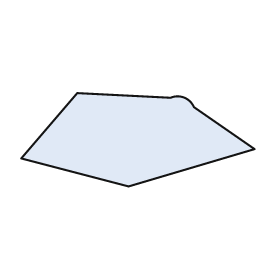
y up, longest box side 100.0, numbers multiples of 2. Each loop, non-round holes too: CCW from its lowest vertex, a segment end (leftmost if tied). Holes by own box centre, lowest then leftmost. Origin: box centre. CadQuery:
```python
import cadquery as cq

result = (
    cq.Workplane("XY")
    .moveTo(-4.0, -20.0)
    .lineTo(50.0, -4.0)
    .lineTo(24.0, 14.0)
    .threePointArc((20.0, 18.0), (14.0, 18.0))
    .lineTo(-26.0, 20.0)
    .lineTo(-50.0, -8.0)
    .close()
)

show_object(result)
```